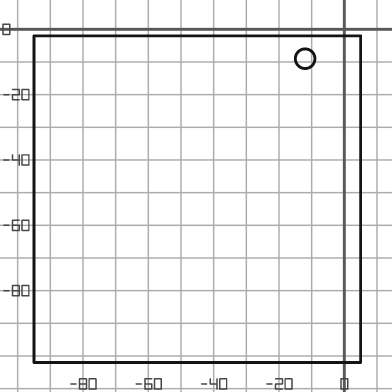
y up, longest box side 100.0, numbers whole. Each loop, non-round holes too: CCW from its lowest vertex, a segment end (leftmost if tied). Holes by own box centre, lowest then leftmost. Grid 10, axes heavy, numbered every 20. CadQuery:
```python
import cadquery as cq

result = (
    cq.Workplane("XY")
    .moveTo(-95.0, -102.0)
    .lineTo(5.0, -102.0)
    .lineTo(5.0, -2.0)
    .lineTo(-95.0, -2.0)
    .close()
    .moveTo(-12.0, -9.0)
    .circle(3.0)
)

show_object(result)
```